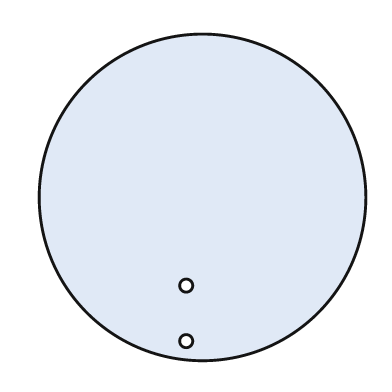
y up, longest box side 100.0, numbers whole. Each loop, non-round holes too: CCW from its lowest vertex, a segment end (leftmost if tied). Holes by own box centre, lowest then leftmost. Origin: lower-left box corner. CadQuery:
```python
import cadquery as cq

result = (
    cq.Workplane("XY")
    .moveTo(50.0, 50.0)
    .circle(50.0)
    .moveTo(45.0, 6.0)
    .circle(2.0)
    .moveTo(45.0, 23.0)
    .circle(2.0)
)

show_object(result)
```